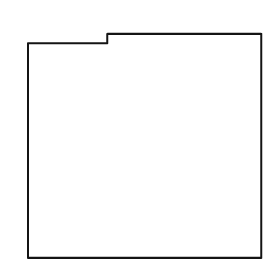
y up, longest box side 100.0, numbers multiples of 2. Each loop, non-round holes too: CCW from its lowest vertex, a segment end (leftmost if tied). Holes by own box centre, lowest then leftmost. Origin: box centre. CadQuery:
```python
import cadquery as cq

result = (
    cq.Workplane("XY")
    .moveTo(-50.0, -48.0)
    .lineTo(50.0, -48.0)
    .lineTo(50.0, 48.0)
    .lineTo(-16.0, 48.0)
    .lineTo(-16.0, 44.0)
    .lineTo(-50.0, 44.0)
    .close()
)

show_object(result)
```